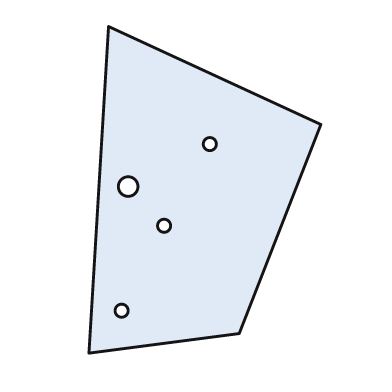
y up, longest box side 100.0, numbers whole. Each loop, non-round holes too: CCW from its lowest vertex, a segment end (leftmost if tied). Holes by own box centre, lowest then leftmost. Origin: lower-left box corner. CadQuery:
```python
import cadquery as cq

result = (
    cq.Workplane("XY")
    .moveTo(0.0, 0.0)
    .lineTo(46.0, 6.0)
    .lineTo(71.0, 70.0)
    .lineTo(6.0, 100.0)
    .close()
    .moveTo(10.0, 13.0)
    .circle(2.0)
    .moveTo(23.0, 39.0)
    .circle(2.0)
    .moveTo(12.0, 51.0)
    .circle(3.0)
    .moveTo(37.0, 64.0)
    .circle(2.0)
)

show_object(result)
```